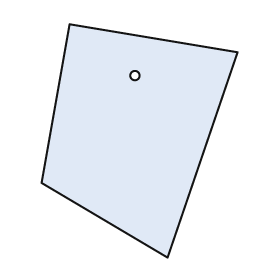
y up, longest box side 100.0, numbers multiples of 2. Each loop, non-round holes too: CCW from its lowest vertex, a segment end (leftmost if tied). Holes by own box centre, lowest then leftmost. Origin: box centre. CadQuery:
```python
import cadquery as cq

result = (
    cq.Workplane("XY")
    .moveTo(12.0, -50.0)
    .lineTo(42.0, 38.0)
    .lineTo(-30.0, 50.0)
    .lineTo(-42.0, -18.0)
    .close()
    .moveTo(-2.0, 28.0)
    .circle(2.0)
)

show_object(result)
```